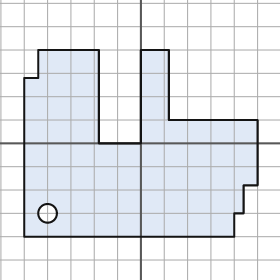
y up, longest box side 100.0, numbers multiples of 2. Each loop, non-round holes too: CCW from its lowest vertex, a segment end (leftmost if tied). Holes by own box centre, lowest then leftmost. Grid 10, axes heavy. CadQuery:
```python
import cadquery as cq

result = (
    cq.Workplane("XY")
    .moveTo(-50.0, -40.0)
    .lineTo(40.0, -40.0)
    .lineTo(40.0, -30.0)
    .lineTo(44.0, -30.0)
    .lineTo(44.0, -18.0)
    .lineTo(50.0, -18.0)
    .lineTo(50.0, 10.0)
    .lineTo(12.0, 10.0)
    .lineTo(12.0, 40.0)
    .lineTo(0.0, 40.0)
    .lineTo(0.0, 0.0)
    .lineTo(-18.0, 0.0)
    .lineTo(-18.0, 40.0)
    .lineTo(-44.0, 40.0)
    .lineTo(-44.0, 28.0)
    .lineTo(-50.0, 28.0)
    .close()
    .moveTo(-40.0, -30.0)
    .circle(4.0)
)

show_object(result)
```